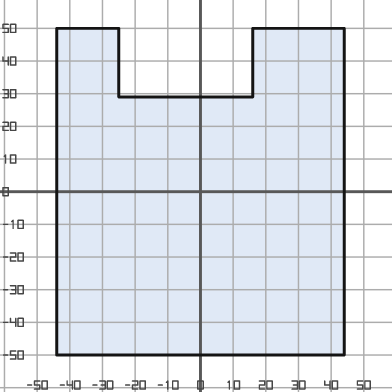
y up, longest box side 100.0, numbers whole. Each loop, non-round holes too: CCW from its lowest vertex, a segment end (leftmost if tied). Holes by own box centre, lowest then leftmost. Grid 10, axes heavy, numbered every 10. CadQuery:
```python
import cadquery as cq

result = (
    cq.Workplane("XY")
    .moveTo(-44.0, -50.0)
    .lineTo(44.0, -50.0)
    .lineTo(44.0, 50.0)
    .lineTo(16.0, 50.0)
    .lineTo(16.0, 29.0)
    .lineTo(-25.0, 29.0)
    .lineTo(-25.0, 50.0)
    .lineTo(-44.0, 50.0)
    .close()
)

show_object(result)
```